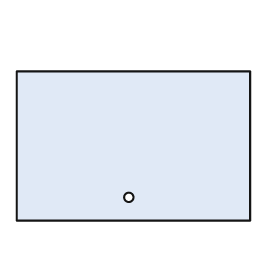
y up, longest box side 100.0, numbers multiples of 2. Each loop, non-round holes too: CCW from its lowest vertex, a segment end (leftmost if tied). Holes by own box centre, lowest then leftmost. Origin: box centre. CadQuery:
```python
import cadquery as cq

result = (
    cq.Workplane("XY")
    .moveTo(-50.0, -32.0)
    .lineTo(50.0, -32.0)
    .lineTo(50.0, 32.0)
    .lineTo(-50.0, 32.0)
    .close()
    .moveTo(-2.0, -22.0)
    .circle(2.0)
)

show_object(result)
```